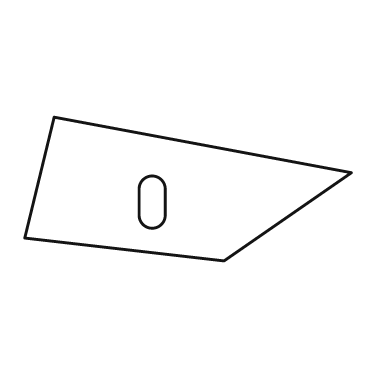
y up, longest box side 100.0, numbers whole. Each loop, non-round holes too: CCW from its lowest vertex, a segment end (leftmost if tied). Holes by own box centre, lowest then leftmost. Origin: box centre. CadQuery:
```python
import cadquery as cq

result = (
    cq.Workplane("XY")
    .moveTo(11.0, -22.0)
    .lineTo(50.0, 5.0)
    .lineTo(-41.0, 22.0)
    .lineTo(-50.0, -15.0)
    .close()
    .moveTo(-15.0, -8.0)
    .threePointArc((-11.0, -12.0), (-7.0, -8.0))
    .lineTo(-7.0, 0.0)
    .threePointArc((-11.0, 4.0), (-15.0, 0.0))
    .close()
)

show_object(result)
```